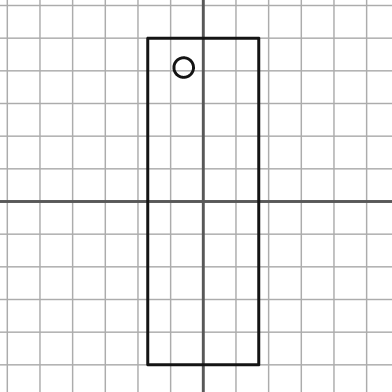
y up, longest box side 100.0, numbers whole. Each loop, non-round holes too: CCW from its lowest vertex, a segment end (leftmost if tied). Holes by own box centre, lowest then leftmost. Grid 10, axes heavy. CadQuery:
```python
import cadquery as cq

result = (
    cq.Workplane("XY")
    .moveTo(-17.0, -50.0)
    .lineTo(17.0, -50.0)
    .lineTo(17.0, 50.0)
    .lineTo(-17.0, 50.0)
    .close()
    .moveTo(-6.0, 41.0)
    .circle(3.0)
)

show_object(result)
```